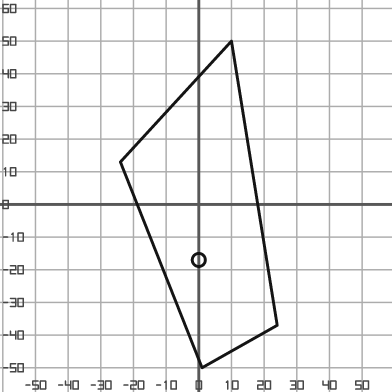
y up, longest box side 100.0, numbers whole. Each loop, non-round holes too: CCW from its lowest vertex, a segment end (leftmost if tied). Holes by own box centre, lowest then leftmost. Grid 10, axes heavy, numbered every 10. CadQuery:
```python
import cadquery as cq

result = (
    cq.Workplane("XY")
    .moveTo(1.0, -50.0)
    .lineTo(24.0, -37.0)
    .lineTo(10.0, 50.0)
    .lineTo(-24.0, 13.0)
    .close()
    .moveTo(0.0, -17.0)
    .circle(2.0)
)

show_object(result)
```